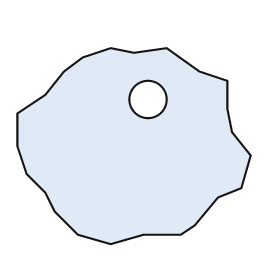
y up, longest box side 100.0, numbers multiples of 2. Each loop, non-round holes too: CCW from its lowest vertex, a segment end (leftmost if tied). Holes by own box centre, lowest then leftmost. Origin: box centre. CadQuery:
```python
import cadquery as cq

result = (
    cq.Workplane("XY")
    .moveTo(-10.0, -42.0)
    .lineTo(4.0, -38.0)
    .lineTo(20.0, -38.0)
    .lineTo(26.0, -34.0)
    .lineTo(36.0, -22.0)
    .lineTo(46.0, -18.0)
    .lineTo(50.0, -4.0)
    .lineTo(42.0, 6.0)
    .lineTo(40.0, 16.0)
    .lineTo(40.0, 28.0)
    .lineTo(28.0, 32.0)
    .lineTo(14.0, 42.0)
    .lineTo(0.0, 40.0)
    .lineTo(-10.0, 42.0)
    .lineTo(-22.0, 38.0)
    .lineTo(-30.0, 32.0)
    .lineTo(-38.0, 22.0)
    .lineTo(-50.0, 14.0)
    .lineTo(-50.0, 0.0)
    .lineTo(-46.0, -12.0)
    .lineTo(-38.0, -20.0)
    .lineTo(-34.0, -28.0)
    .lineTo(-24.0, -38.0)
    .close()
    .moveTo(6.0, 20.0)
    .circle(8.0)
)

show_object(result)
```